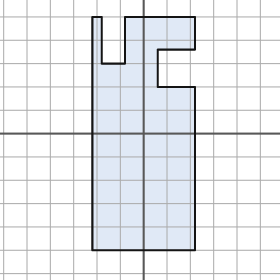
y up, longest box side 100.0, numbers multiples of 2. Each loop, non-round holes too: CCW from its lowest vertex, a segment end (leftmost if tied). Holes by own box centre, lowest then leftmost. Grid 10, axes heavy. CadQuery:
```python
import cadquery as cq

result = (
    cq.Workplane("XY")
    .moveTo(-22.0, -50.0)
    .lineTo(22.0, -50.0)
    .lineTo(22.0, 20.0)
    .lineTo(6.0, 20.0)
    .lineTo(6.0, 36.0)
    .lineTo(22.0, 36.0)
    .lineTo(22.0, 50.0)
    .lineTo(-8.0, 50.0)
    .lineTo(-8.0, 30.0)
    .lineTo(-18.0, 30.0)
    .lineTo(-18.0, 50.0)
    .lineTo(-22.0, 50.0)
    .close()
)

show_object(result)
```